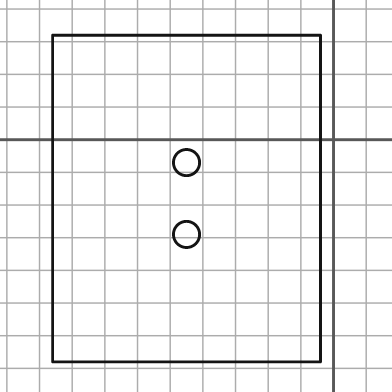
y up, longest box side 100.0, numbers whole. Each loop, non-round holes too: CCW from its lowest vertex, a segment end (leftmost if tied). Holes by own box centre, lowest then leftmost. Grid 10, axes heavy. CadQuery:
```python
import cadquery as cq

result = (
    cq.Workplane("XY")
    .moveTo(-86.0, -68.0)
    .lineTo(-4.0, -68.0)
    .lineTo(-4.0, 32.0)
    .lineTo(-86.0, 32.0)
    .close()
    .moveTo(-45.0, -29.0)
    .circle(4.0)
    .moveTo(-45.0, -7.0)
    .circle(4.0)
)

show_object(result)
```